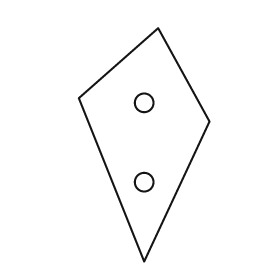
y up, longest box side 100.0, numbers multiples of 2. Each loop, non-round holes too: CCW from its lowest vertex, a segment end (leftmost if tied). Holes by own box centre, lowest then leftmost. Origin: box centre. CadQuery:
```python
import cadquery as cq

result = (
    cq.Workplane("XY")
    .moveTo(0.0, -50.0)
    .lineTo(28.0, 10.0)
    .lineTo(6.0, 50.0)
    .lineTo(-28.0, 20.0)
    .close()
    .moveTo(0.0, -16.0)
    .circle(4.0)
    .moveTo(0.0, 18.0)
    .circle(4.0)
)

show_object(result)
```